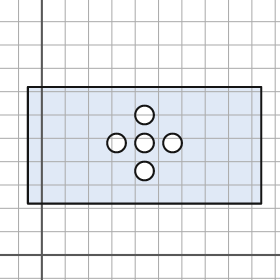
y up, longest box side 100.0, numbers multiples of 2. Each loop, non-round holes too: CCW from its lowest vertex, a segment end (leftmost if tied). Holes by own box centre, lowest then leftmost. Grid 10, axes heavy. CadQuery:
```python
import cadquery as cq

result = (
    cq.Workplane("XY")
    .moveTo(-6.0, 22.0)
    .lineTo(94.0, 22.0)
    .lineTo(94.0, 72.0)
    .lineTo(-6.0, 72.0)
    .close()
    .moveTo(44.0, 36.0)
    .circle(4.0)
    .moveTo(32.0, 48.0)
    .circle(4.0)
    .moveTo(44.0, 48.0)
    .circle(4.0)
    .moveTo(56.0, 48.0)
    .circle(4.0)
    .moveTo(44.0, 60.0)
    .circle(4.0)
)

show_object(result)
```